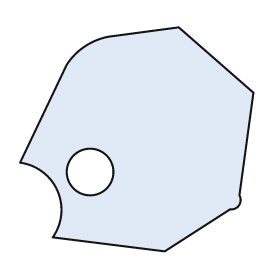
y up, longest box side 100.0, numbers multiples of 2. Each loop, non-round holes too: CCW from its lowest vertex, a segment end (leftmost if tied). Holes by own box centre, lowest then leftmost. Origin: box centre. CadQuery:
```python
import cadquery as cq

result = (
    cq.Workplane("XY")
    .moveTo(12.0, -48.0)
    .lineTo(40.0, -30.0)
    .threePointArc((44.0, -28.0), (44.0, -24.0))
    .lineTo(50.0, 20.0)
    .lineTo(18.0, 48.0)
    .lineTo(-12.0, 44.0)
    .threePointArc((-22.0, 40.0), (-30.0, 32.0))
    .lineTo(-50.0, -10.0)
    .threePointArc((-34.0, -22.0), (-36.0, -42.0))
    .close()
    .moveTo(-20.0, -14.0)
    .circle(10.0)
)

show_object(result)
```